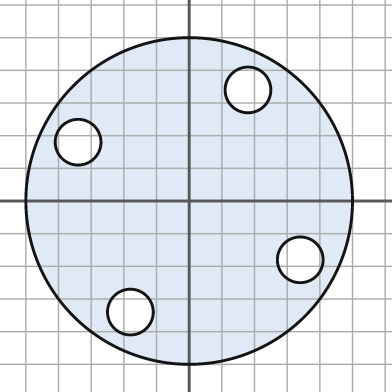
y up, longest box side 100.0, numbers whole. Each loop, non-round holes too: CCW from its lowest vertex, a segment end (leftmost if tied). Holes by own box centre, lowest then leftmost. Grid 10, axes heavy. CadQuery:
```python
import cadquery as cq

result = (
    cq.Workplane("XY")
    .moveTo(0.0, 0.0)
    .circle(50.0)
    .moveTo(-18.0, -34.0)
    .circle(7.0)
    .moveTo(34.0, -18.0)
    .circle(7.0)
    .moveTo(-34.0, 18.0)
    .circle(7.0)
    .moveTo(18.0, 34.0)
    .circle(7.0)
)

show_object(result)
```